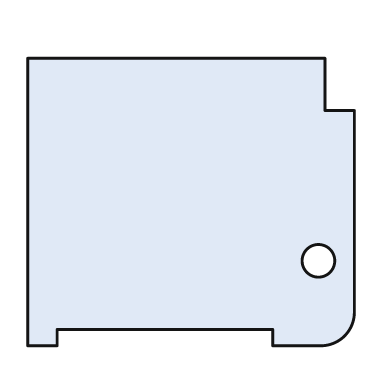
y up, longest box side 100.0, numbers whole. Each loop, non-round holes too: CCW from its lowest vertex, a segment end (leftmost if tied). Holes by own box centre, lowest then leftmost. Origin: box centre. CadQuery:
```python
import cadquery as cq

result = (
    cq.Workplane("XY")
    .moveTo(-50.0, -44.0)
    .lineTo(-41.0, -44.0)
    .lineTo(-41.0, -39.0)
    .lineTo(25.0, -39.0)
    .lineTo(25.0, -44.0)
    .lineTo(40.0, -44.0)
    .threePointArc((47.0, -41.0), (50.0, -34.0))
    .lineTo(50.0, 28.0)
    .lineTo(41.0, 28.0)
    .lineTo(41.0, 44.0)
    .lineTo(-50.0, 44.0)
    .close()
    .moveTo(39.0, -18.0)
    .circle(5.0)
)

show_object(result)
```